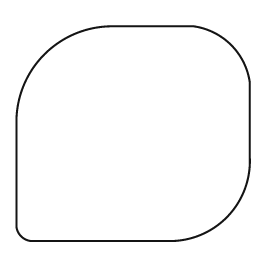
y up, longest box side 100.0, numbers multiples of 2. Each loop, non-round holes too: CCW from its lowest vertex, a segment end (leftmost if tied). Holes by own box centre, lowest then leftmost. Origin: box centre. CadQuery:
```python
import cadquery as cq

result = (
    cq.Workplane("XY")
    .moveTo(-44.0, -46.0)
    .lineTo(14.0, -46.0)
    .threePointArc((40.0, -36.0), (50.0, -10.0))
    .lineTo(50.0, 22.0)
    .threePointArc((42.0, 38.0), (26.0, 46.0))
    .lineTo(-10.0, 46.0)
    .threePointArc((-38.0, 34.0), (-50.0, 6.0))
    .lineTo(-50.0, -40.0)
    .threePointArc((-48.0, -44.0), (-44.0, -46.0))
    .close()
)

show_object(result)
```